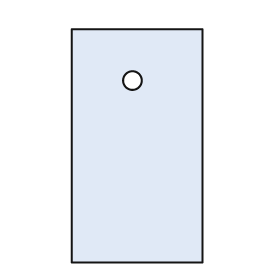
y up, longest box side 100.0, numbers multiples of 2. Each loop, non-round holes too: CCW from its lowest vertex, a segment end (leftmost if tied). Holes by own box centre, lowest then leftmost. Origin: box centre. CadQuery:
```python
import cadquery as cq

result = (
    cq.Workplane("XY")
    .moveTo(-28.0, -50.0)
    .lineTo(28.0, -50.0)
    .lineTo(28.0, 50.0)
    .lineTo(-28.0, 50.0)
    .close()
    .moveTo(-2.0, 28.0)
    .circle(4.0)
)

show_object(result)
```